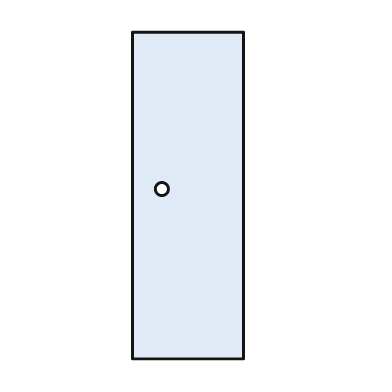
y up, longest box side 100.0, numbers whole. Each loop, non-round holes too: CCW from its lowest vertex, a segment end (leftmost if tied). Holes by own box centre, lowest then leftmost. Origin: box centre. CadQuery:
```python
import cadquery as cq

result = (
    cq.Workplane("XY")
    .moveTo(-17.0, -50.0)
    .lineTo(17.0, -50.0)
    .lineTo(17.0, 50.0)
    .lineTo(-17.0, 50.0)
    .close()
    .moveTo(-8.0, 2.0)
    .circle(2.0)
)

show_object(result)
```